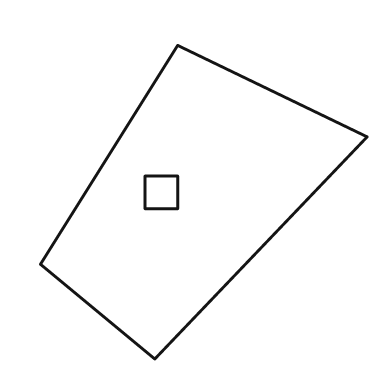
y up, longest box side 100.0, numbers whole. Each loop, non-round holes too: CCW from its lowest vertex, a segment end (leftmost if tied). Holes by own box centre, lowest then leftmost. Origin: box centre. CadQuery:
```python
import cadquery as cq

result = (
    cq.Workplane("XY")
    .moveTo(-15.0, -48.0)
    .lineTo(50.0, 20.0)
    .lineTo(-8.0, 48.0)
    .lineTo(-50.0, -19.0)
    .close()
    .moveTo(-18.0, -2.0)
    .lineTo(-8.0, -2.0)
    .lineTo(-8.0, 8.0)
    .lineTo(-18.0, 8.0)
    .close()
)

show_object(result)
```